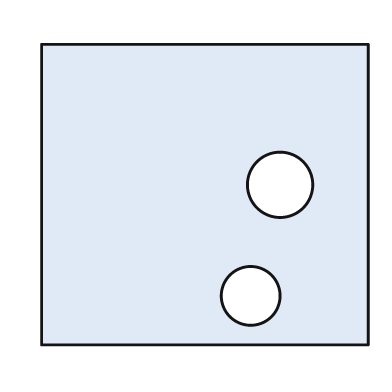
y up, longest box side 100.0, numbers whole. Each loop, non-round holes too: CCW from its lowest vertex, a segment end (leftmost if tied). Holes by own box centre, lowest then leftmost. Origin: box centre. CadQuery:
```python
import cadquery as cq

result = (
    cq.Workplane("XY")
    .moveTo(-50.0, -46.0)
    .lineTo(50.0, -46.0)
    .lineTo(50.0, 46.0)
    .lineTo(-50.0, 46.0)
    .close()
    .moveTo(14.0, -31.0)
    .circle(9.0)
    .moveTo(23.0, 3.0)
    .circle(10.0)
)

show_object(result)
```